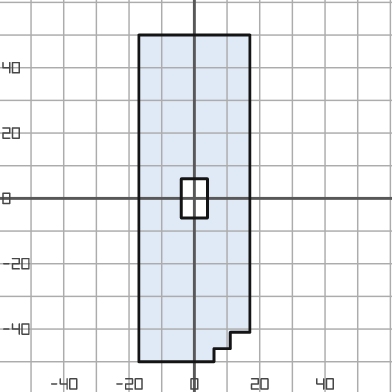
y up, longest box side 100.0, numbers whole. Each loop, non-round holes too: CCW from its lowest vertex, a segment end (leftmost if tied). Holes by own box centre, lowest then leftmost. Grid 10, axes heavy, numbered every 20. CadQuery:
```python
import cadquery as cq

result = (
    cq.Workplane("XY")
    .moveTo(-17.0, -50.0)
    .lineTo(6.0, -50.0)
    .lineTo(6.0, -46.0)
    .lineTo(11.0, -46.0)
    .lineTo(11.0, -41.0)
    .lineTo(17.0, -41.0)
    .lineTo(17.0, 50.0)
    .lineTo(-17.0, 50.0)
    .close()
    .moveTo(-4.0, -6.0)
    .lineTo(4.0, -6.0)
    .lineTo(4.0, 6.0)
    .lineTo(-4.0, 6.0)
    .close()
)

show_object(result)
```